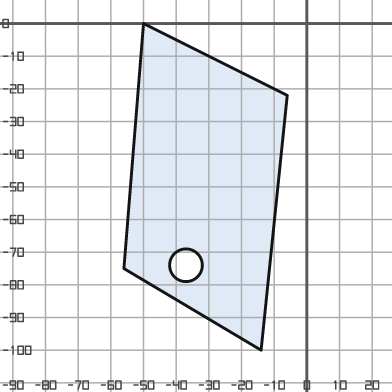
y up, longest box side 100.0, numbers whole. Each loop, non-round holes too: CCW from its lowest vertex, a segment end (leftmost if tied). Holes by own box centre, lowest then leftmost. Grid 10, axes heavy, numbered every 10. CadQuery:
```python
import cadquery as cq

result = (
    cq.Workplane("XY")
    .moveTo(-14.0, -100.0)
    .lineTo(-6.0, -22.0)
    .lineTo(-50.0, 0.0)
    .lineTo(-56.0, -75.0)
    .close()
    .moveTo(-37.0, -74.0)
    .circle(5.0)
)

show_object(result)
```